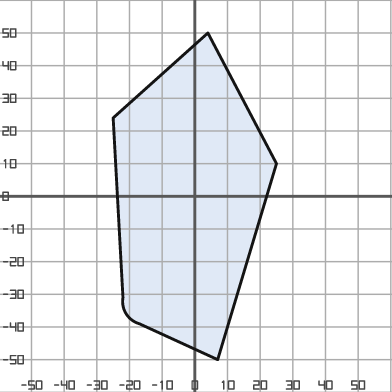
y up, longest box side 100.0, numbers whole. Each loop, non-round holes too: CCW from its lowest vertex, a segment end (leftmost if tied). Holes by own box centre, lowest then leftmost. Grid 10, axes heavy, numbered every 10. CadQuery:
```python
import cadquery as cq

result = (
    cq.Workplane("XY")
    .moveTo(7.0, -50.0)
    .lineTo(25.0, 10.0)
    .lineTo(4.0, 50.0)
    .lineTo(-25.0, 24.0)
    .lineTo(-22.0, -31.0)
    .threePointArc((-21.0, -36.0), (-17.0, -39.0))
    .close()
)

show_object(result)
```